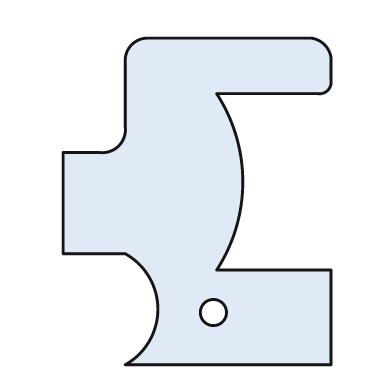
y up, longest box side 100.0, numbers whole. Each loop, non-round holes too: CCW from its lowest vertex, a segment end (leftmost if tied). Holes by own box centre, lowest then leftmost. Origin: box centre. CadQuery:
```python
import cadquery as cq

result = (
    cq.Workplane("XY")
    .moveTo(-22.0, -50.0)
    .lineTo(41.0, -50.0)
    .lineTo(41.0, -21.0)
    .lineTo(6.0, -21.0)
    .threePointArc((14.0, 6.0), (6.0, 33.0))
    .lineTo(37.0, 33.0)
    .threePointArc((40.0, 34.0), (41.0, 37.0))
    .lineTo(41.0, 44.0)
    .threePointArc((39.0, 48.0), (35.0, 50.0))
    .lineTo(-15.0, 50.0)
    .threePointArc((-20.0, 48.0), (-22.0, 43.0))
    .lineTo(-22.0, 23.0)
    .threePointArc((-24.0, 17.0), (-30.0, 15.0))
    .lineTo(-41.0, 15.0)
    .lineTo(-41.0, -16.0)
    .lineTo(-22.0, -16.0)
    .threePointArc((-12.0, -33.0), (-22.0, -50.0))
    .close()
    .moveTo(5.0, -34.0)
    .circle(4.0)
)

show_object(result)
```